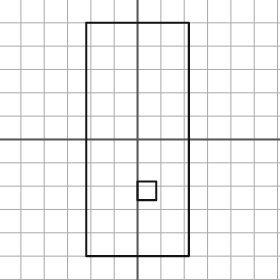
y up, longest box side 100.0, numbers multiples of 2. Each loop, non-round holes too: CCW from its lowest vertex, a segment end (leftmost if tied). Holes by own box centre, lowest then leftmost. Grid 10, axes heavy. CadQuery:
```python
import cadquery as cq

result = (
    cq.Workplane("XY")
    .moveTo(-22.0, -50.0)
    .lineTo(22.0, -50.0)
    .lineTo(22.0, 50.0)
    .lineTo(-22.0, 50.0)
    .close()
    .moveTo(0.0, -26.0)
    .lineTo(8.0, -26.0)
    .lineTo(8.0, -18.0)
    .lineTo(0.0, -18.0)
    .close()
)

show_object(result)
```